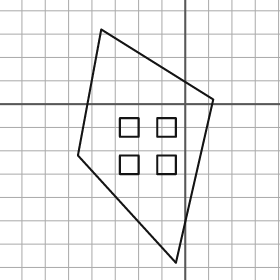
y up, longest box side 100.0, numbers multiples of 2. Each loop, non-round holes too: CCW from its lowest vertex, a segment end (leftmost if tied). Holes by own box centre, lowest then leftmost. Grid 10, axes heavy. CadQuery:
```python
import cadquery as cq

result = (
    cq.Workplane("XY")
    .moveTo(-4.0, -68.0)
    .lineTo(12.0, 2.0)
    .lineTo(-36.0, 32.0)
    .lineTo(-46.0, -22.0)
    .close()
    .moveTo(-28.0, -30.0)
    .lineTo(-20.0, -30.0)
    .lineTo(-20.0, -22.0)
    .lineTo(-28.0, -22.0)
    .close()
    .moveTo(-12.0, -30.0)
    .lineTo(-4.0, -30.0)
    .lineTo(-4.0, -22.0)
    .lineTo(-12.0, -22.0)
    .close()
    .moveTo(-28.0, -14.0)
    .lineTo(-20.0, -14.0)
    .lineTo(-20.0, -6.0)
    .lineTo(-28.0, -6.0)
    .close()
    .moveTo(-12.0, -14.0)
    .lineTo(-4.0, -14.0)
    .lineTo(-4.0, -6.0)
    .lineTo(-12.0, -6.0)
    .close()
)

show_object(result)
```